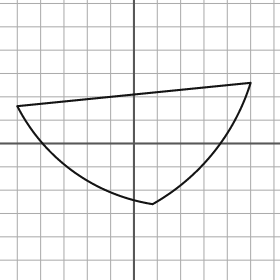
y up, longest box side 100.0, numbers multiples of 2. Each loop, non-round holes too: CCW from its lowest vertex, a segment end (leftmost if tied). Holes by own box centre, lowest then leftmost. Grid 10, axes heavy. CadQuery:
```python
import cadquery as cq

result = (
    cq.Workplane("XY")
    .moveTo(8.0, -26.0)
    .threePointArc((34.0, -4.0), (50.0, 26.0))
    .lineTo(-50.0, 16.0)
    .threePointArc((-26.0, -12.0), (8.0, -26.0))
    .close()
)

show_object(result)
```